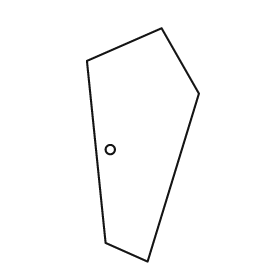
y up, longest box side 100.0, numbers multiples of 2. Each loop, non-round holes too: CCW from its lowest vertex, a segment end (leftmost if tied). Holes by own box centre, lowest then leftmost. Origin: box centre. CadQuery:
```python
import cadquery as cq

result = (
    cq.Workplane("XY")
    .moveTo(2.0, -50.0)
    .lineTo(24.0, 22.0)
    .lineTo(8.0, 50.0)
    .lineTo(-24.0, 36.0)
    .lineTo(-16.0, -42.0)
    .close()
    .moveTo(-14.0, -2.0)
    .circle(2.0)
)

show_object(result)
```